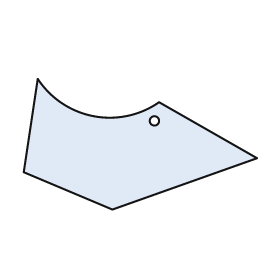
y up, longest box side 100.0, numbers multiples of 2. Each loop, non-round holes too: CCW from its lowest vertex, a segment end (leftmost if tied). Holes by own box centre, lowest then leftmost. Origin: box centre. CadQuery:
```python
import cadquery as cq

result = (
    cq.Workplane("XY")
    .moveTo(-12.0, -28.0)
    .lineTo(50.0, -6.0)
    .lineTo(8.0, 18.0)
    .threePointArc((-20.0, 12.0), (-44.0, 28.0))
    .lineTo(-50.0, -12.0)
    .close()
    .moveTo(6.0, 10.0)
    .circle(2.0)
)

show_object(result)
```